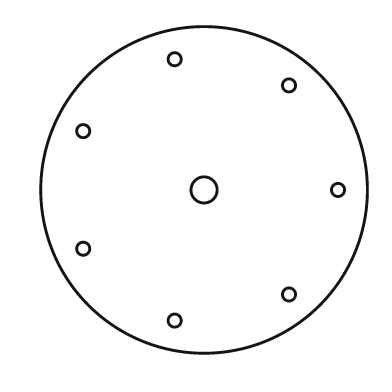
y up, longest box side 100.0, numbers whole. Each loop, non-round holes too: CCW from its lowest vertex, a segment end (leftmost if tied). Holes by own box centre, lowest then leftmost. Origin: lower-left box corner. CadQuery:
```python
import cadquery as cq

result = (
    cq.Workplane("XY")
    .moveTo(50.0, 50.0)
    .circle(50.0)
    .moveTo(41.0, 10.0)
    .circle(2.0)
    .moveTo(76.0, 18.0)
    .circle(2.0)
    .moveTo(13.0, 32.0)
    .circle(2.0)
    .moveTo(50.0, 50.0)
    .circle(4.0)
    .moveTo(91.0, 50.0)
    .circle(2.0)
    .moveTo(13.0, 68.0)
    .circle(2.0)
    .moveTo(76.0, 82.0)
    .circle(2.0)
    .moveTo(41.0, 90.0)
    .circle(2.0)
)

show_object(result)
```